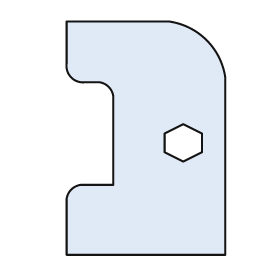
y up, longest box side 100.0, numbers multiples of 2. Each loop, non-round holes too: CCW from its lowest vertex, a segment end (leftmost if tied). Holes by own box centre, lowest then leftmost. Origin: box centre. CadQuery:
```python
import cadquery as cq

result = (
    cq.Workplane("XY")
    .moveTo(-34.0, -50.0)
    .lineTo(34.0, -50.0)
    .lineTo(34.0, 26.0)
    .threePointArc((26.0, 42.0), (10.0, 50.0))
    .lineTo(-34.0, 50.0)
    .lineTo(-34.0, 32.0)
    .threePointArc((-32.0, 26.0), (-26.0, 24.0))
    .lineTo(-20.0, 24.0)
    .threePointArc((-16.0, 22.0), (-14.0, 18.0))
    .lineTo(-14.0, -20.0)
    .lineTo(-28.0, -20.0)
    .threePointArc((-32.0, -22.0), (-34.0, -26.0))
    .close()
    .moveTo(16.0, -10.0)
    .lineTo(24.0, -6.0)
    .lineTo(24.0, 2.0)
    .lineTo(16.0, 6.0)
    .lineTo(8.0, 2.0)
    .lineTo(8.0, -6.0)
    .close()
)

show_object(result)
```